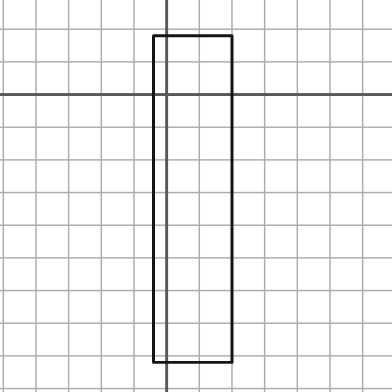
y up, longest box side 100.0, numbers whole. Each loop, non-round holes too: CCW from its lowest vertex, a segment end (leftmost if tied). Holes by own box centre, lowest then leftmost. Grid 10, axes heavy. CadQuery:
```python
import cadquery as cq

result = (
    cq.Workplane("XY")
    .moveTo(-4.0, -82.0)
    .lineTo(20.0, -82.0)
    .lineTo(20.0, 18.0)
    .lineTo(-4.0, 18.0)
    .close()
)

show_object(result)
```